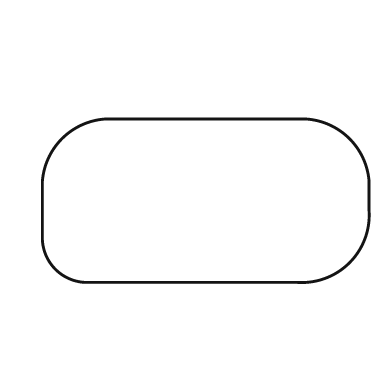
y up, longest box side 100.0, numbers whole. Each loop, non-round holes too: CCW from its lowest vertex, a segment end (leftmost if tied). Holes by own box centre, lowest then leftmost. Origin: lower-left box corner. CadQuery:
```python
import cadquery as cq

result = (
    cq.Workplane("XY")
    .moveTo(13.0, 0.0)
    .lineTo(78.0, 0.0)
    .threePointArc((94.0, 6.0), (100.0, 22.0))
    .lineTo(100.0, 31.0)
    .threePointArc((94.0, 44.0), (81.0, 50.0))
    .lineTo(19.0, 50.0)
    .threePointArc((6.0, 44.0), (0.0, 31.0))
    .lineTo(0.0, 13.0)
    .threePointArc((4.0, 4.0), (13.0, 0.0))
    .close()
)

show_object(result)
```